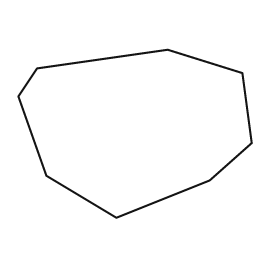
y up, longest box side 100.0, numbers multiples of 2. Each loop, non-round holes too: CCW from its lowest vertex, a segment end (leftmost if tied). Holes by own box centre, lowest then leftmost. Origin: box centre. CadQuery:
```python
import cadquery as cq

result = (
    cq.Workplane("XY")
    .moveTo(-8.0, -36.0)
    .lineTo(32.0, -20.0)
    .lineTo(50.0, -4.0)
    .lineTo(46.0, 26.0)
    .lineTo(14.0, 36.0)
    .lineTo(-42.0, 28.0)
    .lineTo(-50.0, 16.0)
    .lineTo(-38.0, -18.0)
    .close()
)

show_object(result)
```